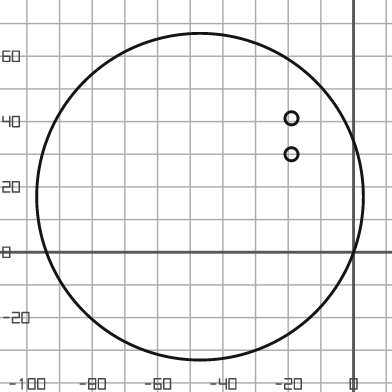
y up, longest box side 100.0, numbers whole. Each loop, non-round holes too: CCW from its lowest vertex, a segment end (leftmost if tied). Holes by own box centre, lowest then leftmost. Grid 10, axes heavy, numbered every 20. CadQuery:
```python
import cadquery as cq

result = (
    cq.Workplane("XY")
    .moveTo(-47.0, 17.0)
    .circle(50.0)
    .moveTo(-19.0, 30.0)
    .circle(2.0)
    .moveTo(-19.0, 41.0)
    .circle(2.0)
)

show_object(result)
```